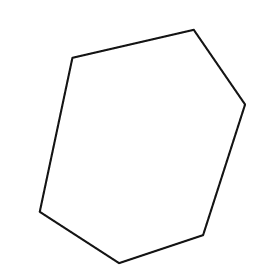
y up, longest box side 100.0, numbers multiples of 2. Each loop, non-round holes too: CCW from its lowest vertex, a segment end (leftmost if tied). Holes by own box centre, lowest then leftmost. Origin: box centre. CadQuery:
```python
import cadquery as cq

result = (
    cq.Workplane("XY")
    .moveTo(-10.0, -50.0)
    .lineTo(26.0, -38.0)
    .lineTo(44.0, 18.0)
    .lineTo(22.0, 50.0)
    .lineTo(-30.0, 38.0)
    .lineTo(-44.0, -28.0)
    .close()
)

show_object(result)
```